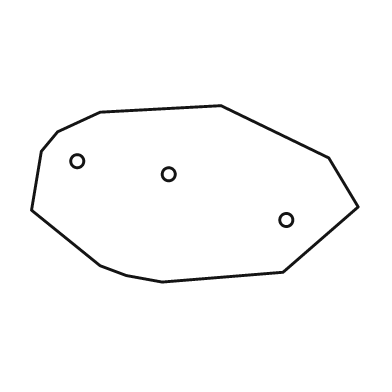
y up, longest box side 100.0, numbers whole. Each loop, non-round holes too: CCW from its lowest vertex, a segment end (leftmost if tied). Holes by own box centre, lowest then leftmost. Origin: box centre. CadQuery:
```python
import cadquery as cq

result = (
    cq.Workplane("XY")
    .moveTo(-10.0, -27.0)
    .lineTo(27.0, -24.0)
    .lineTo(50.0, -4.0)
    .lineTo(41.0, 11.0)
    .lineTo(8.0, 27.0)
    .lineTo(-29.0, 25.0)
    .lineTo(-42.0, 19.0)
    .lineTo(-47.0, 13.0)
    .lineTo(-50.0, -5.0)
    .lineTo(-29.0, -22.0)
    .lineTo(-21.0, -25.0)
    .close()
    .moveTo(28.0, -8.0)
    .circle(2.0)
    .moveTo(-8.0, 6.0)
    .circle(2.0)
    .moveTo(-36.0, 10.0)
    .circle(2.0)
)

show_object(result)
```